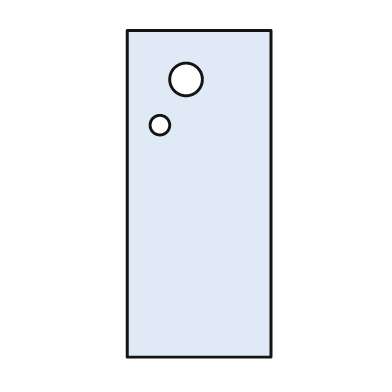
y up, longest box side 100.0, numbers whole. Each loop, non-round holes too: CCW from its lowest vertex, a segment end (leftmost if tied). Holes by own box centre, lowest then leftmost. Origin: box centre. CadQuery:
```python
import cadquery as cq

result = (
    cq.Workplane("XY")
    .moveTo(-22.0, -50.0)
    .lineTo(22.0, -50.0)
    .lineTo(22.0, 50.0)
    .lineTo(-22.0, 50.0)
    .close()
    .moveTo(-12.0, 21.0)
    .circle(3.0)
    .moveTo(-4.0, 35.0)
    .circle(5.0)
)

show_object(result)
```